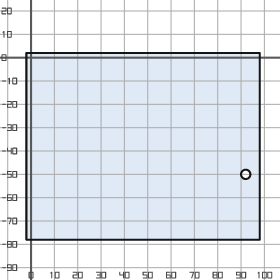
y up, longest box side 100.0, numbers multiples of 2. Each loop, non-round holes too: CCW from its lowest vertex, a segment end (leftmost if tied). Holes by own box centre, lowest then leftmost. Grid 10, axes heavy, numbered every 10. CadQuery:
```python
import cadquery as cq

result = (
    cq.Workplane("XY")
    .moveTo(-2.0, -78.0)
    .lineTo(98.0, -78.0)
    .lineTo(98.0, 2.0)
    .lineTo(-2.0, 2.0)
    .close()
    .moveTo(92.0, -50.0)
    .circle(2.0)
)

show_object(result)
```